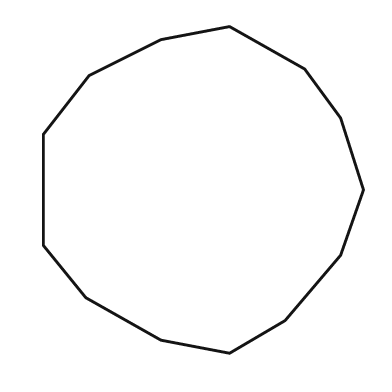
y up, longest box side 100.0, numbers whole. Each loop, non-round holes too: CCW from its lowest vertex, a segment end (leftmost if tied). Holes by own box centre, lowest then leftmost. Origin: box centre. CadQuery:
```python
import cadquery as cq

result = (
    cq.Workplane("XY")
    .moveTo(8.0, -50.0)
    .lineTo(25.0, -40.0)
    .lineTo(42.0, -20.0)
    .lineTo(49.0, 0.0)
    .lineTo(42.0, 22.0)
    .lineTo(31.0, 37.0)
    .lineTo(8.0, 50.0)
    .lineTo(-13.0, 46.0)
    .lineTo(-35.0, 35.0)
    .lineTo(-49.0, 17.0)
    .lineTo(-49.0, -17.0)
    .lineTo(-36.0, -33.0)
    .lineTo(-13.0, -46.0)
    .close()
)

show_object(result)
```